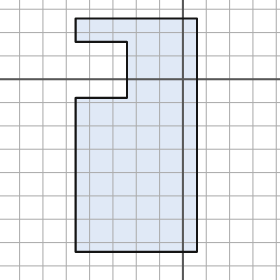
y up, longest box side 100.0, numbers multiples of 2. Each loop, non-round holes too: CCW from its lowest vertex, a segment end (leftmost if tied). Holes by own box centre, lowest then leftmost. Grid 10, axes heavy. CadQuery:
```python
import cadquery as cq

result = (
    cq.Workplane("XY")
    .moveTo(-46.0, -74.0)
    .lineTo(6.0, -74.0)
    .lineTo(6.0, 26.0)
    .lineTo(-46.0, 26.0)
    .lineTo(-46.0, 16.0)
    .lineTo(-24.0, 16.0)
    .lineTo(-24.0, -8.0)
    .lineTo(-46.0, -8.0)
    .close()
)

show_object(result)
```